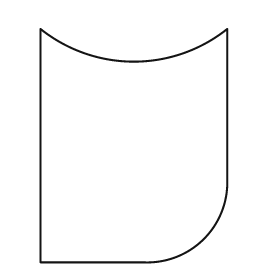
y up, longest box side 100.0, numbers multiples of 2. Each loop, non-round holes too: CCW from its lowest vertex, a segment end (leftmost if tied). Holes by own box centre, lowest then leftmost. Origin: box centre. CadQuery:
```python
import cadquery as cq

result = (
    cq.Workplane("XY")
    .moveTo(-40.0, -50.0)
    .lineTo(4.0, -50.0)
    .threePointArc((30.0, -40.0), (40.0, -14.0))
    .lineTo(40.0, 50.0)
    .threePointArc((0.0, 36.0), (-40.0, 50.0))
    .close()
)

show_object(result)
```